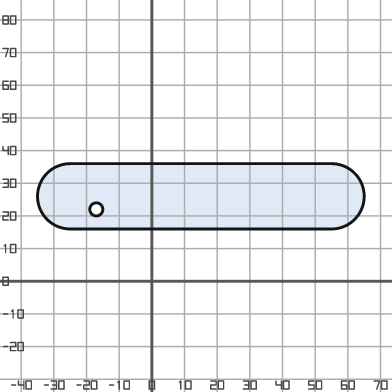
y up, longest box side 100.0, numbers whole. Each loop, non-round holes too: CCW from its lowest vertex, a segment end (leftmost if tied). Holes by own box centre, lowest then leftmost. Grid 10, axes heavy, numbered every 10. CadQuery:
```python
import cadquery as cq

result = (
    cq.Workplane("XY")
    .moveTo(-25.0, 16.0)
    .lineTo(55.0, 16.0)
    .threePointArc((65.0, 26.0), (55.0, 36.0))
    .lineTo(-25.0, 36.0)
    .threePointArc((-35.0, 26.0), (-25.0, 16.0))
    .close()
    .moveTo(-17.0, 22.0)
    .circle(2.0)
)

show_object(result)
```